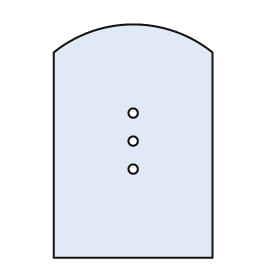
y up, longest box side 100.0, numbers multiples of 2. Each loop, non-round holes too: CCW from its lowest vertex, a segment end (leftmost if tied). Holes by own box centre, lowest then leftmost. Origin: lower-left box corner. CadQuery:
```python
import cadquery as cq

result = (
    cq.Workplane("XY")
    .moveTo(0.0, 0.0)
    .lineTo(68.0, 0.0)
    .lineTo(68.0, 88.0)
    .threePointArc((34.0, 100.0), (0.0, 88.0))
    .close()
    .moveTo(34.0, 38.0)
    .circle(2.0)
    .moveTo(34.0, 50.0)
    .circle(2.0)
    .moveTo(34.0, 62.0)
    .circle(2.0)
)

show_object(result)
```